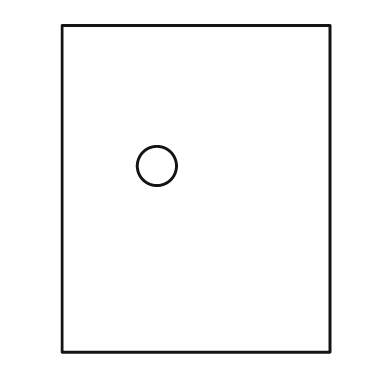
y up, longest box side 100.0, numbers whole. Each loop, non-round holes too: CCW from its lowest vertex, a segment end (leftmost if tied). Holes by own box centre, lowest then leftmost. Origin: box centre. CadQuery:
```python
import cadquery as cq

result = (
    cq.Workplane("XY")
    .moveTo(-41.0, -50.0)
    .lineTo(41.0, -50.0)
    .lineTo(41.0, 50.0)
    .lineTo(-41.0, 50.0)
    .close()
    .moveTo(-12.0, 7.0)
    .circle(6.0)
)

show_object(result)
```